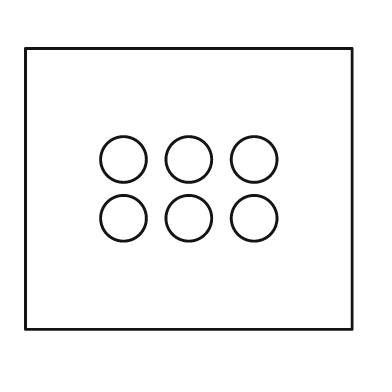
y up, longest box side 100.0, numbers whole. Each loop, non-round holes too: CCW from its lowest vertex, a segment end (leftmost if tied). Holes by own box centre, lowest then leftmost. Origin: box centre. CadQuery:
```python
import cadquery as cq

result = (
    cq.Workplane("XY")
    .moveTo(-50.0, -43.0)
    .lineTo(50.0, -43.0)
    .lineTo(50.0, 43.0)
    .lineTo(-50.0, 43.0)
    .close()
    .moveTo(-20.0, -9.0)
    .circle(7.0)
    .moveTo(0.0, -9.0)
    .circle(7.0)
    .moveTo(20.0, -9.0)
    .circle(7.0)
    .moveTo(-20.0, 9.0)
    .circle(7.0)
    .moveTo(0.0, 9.0)
    .circle(7.0)
    .moveTo(20.0, 9.0)
    .circle(7.0)
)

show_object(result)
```